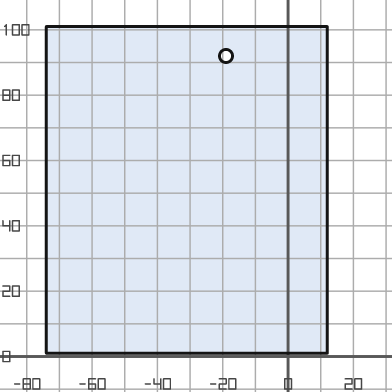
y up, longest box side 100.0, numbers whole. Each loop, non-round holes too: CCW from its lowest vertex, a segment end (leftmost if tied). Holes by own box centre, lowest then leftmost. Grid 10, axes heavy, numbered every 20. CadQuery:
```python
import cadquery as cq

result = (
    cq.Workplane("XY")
    .moveTo(-74.0, 1.0)
    .lineTo(12.0, 1.0)
    .lineTo(12.0, 101.0)
    .lineTo(-74.0, 101.0)
    .close()
    .moveTo(-19.0, 92.0)
    .circle(2.0)
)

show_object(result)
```